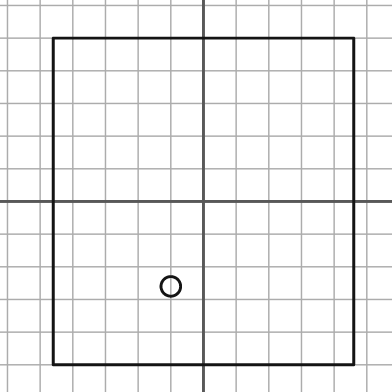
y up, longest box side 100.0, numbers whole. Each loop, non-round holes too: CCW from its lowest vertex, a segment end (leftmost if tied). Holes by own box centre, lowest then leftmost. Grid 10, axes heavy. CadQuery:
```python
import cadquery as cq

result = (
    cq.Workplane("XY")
    .moveTo(-46.0, -50.0)
    .lineTo(46.0, -50.0)
    .lineTo(46.0, 50.0)
    .lineTo(-46.0, 50.0)
    .close()
    .moveTo(-10.0, -26.0)
    .circle(3.0)
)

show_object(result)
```